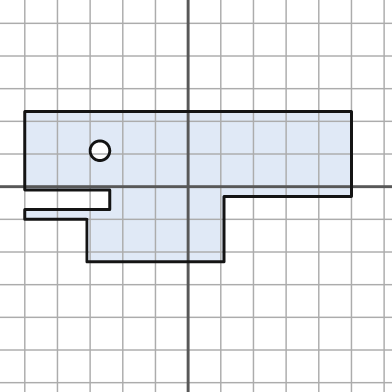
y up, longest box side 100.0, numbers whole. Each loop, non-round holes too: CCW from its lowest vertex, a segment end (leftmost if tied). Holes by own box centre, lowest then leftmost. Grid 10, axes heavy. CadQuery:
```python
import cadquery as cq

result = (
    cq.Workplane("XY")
    .moveTo(-31.0, -23.0)
    .lineTo(11.0, -23.0)
    .lineTo(11.0, -3.0)
    .lineTo(50.0, -3.0)
    .lineTo(50.0, 23.0)
    .lineTo(-50.0, 23.0)
    .lineTo(-50.0, -1.0)
    .lineTo(-24.0, -1.0)
    .lineTo(-24.0, -7.0)
    .lineTo(-50.0, -7.0)
    .lineTo(-50.0, -10.0)
    .lineTo(-31.0, -10.0)
    .close()
    .moveTo(-27.0, 11.0)
    .circle(3.0)
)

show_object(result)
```